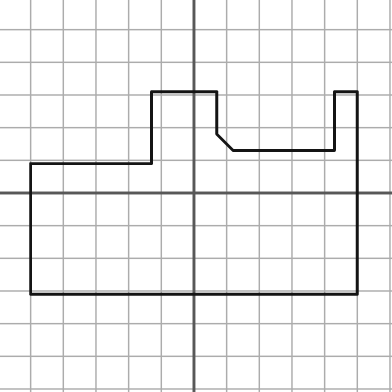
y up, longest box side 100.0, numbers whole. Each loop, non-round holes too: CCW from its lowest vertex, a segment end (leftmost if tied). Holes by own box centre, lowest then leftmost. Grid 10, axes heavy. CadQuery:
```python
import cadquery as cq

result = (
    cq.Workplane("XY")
    .moveTo(-50.0, -31.0)
    .lineTo(50.0, -31.0)
    .lineTo(50.0, 31.0)
    .lineTo(43.0, 31.0)
    .lineTo(43.0, 13.0)
    .lineTo(12.0, 13.0)
    .lineTo(7.0, 18.0)
    .lineTo(7.0, 31.0)
    .lineTo(-13.0, 31.0)
    .lineTo(-13.0, 9.0)
    .lineTo(-50.0, 9.0)
    .close()
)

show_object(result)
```